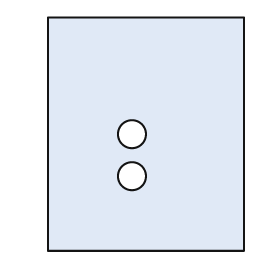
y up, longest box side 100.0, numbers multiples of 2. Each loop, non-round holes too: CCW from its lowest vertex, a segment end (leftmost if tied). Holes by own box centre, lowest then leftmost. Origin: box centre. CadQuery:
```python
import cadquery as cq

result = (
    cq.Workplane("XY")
    .moveTo(-42.0, -50.0)
    .lineTo(42.0, -50.0)
    .lineTo(42.0, 50.0)
    .lineTo(-42.0, 50.0)
    .close()
    .moveTo(-6.0, -18.0)
    .circle(6.0)
    .moveTo(-6.0, 0.0)
    .circle(6.0)
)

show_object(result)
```